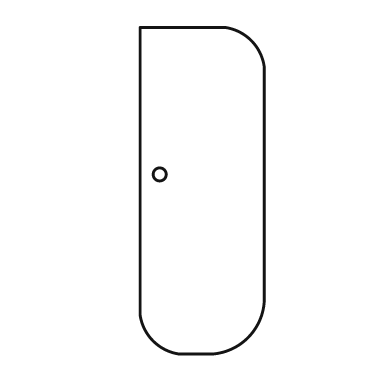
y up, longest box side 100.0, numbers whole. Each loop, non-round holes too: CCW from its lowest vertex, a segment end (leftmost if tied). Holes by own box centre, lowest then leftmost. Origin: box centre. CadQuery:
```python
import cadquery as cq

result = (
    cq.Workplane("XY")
    .moveTo(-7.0, -50.0)
    .lineTo(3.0, -50.0)
    .threePointArc((14.0, -45.0), (19.0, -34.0))
    .lineTo(19.0, 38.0)
    .threePointArc((15.0, 46.0), (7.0, 50.0))
    .lineTo(-19.0, 50.0)
    .lineTo(-19.0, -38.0)
    .threePointArc((-15.0, -46.0), (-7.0, -50.0))
    .close()
    .moveTo(-13.0, 5.0)
    .circle(2.0)
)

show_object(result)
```